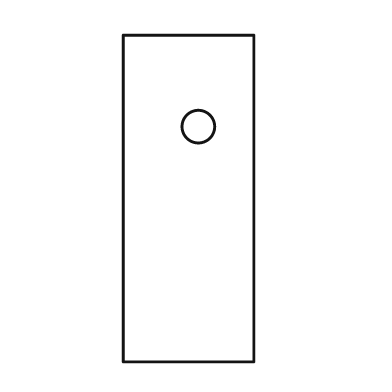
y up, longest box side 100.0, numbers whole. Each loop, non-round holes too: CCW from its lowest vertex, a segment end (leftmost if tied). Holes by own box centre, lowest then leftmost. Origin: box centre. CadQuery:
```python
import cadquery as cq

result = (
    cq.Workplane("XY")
    .moveTo(-20.0, -50.0)
    .lineTo(20.0, -50.0)
    .lineTo(20.0, 50.0)
    .lineTo(-20.0, 50.0)
    .close()
    .moveTo(3.0, 22.0)
    .circle(5.0)
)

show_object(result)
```